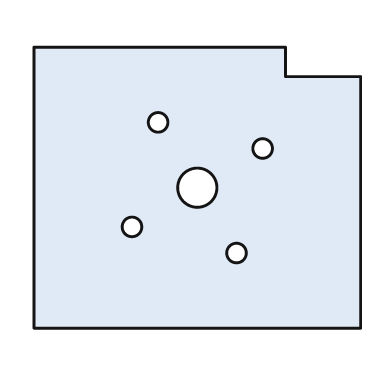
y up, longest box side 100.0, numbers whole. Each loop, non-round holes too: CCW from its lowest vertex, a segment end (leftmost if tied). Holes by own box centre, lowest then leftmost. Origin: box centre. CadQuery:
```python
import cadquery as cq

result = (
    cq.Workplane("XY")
    .moveTo(-50.0, -43.0)
    .lineTo(50.0, -43.0)
    .lineTo(50.0, 34.0)
    .lineTo(27.0, 34.0)
    .lineTo(27.0, 43.0)
    .lineTo(-50.0, 43.0)
    .close()
    .moveTo(12.0, -20.0)
    .circle(3.0)
    .moveTo(-20.0, -12.0)
    .circle(3.0)
    .moveTo(0.0, 0.0)
    .circle(6.0)
    .moveTo(20.0, 12.0)
    .circle(3.0)
    .moveTo(-12.0, 20.0)
    .circle(3.0)
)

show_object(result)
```